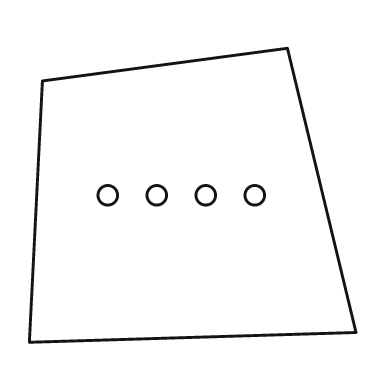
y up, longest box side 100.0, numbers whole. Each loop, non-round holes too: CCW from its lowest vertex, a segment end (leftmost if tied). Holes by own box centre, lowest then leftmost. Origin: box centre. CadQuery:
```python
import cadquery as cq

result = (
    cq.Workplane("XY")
    .moveTo(-50.0, -45.0)
    .lineTo(50.0, -42.0)
    .lineTo(29.0, 45.0)
    .lineTo(-46.0, 35.0)
    .close()
    .moveTo(-26.0, 0.0)
    .circle(3.0)
    .moveTo(-11.0, 0.0)
    .circle(3.0)
    .moveTo(4.0, 0.0)
    .circle(3.0)
    .moveTo(19.0, 0.0)
    .circle(3.0)
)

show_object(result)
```